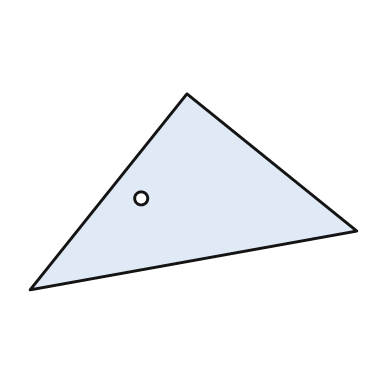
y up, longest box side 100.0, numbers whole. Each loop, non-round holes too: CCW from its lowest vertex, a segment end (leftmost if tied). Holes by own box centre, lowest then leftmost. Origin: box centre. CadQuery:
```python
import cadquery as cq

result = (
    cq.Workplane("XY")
    .moveTo(-50.0, -30.0)
    .lineTo(50.0, -12.0)
    .lineTo(-2.0, 30.0)
    .close()
    .moveTo(-16.0, -2.0)
    .circle(2.0)
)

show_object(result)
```